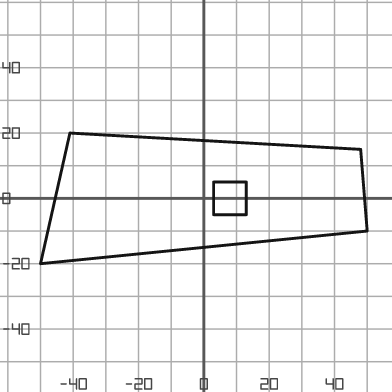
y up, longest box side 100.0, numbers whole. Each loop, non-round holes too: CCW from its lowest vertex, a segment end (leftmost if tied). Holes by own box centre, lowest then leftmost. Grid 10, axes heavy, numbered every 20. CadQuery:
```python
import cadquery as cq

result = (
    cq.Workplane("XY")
    .moveTo(-50.0, -20.0)
    .lineTo(50.0, -10.0)
    .lineTo(48.0, 15.0)
    .lineTo(-41.0, 20.0)
    .close()
    .moveTo(3.0, -5.0)
    .lineTo(13.0, -5.0)
    .lineTo(13.0, 5.0)
    .lineTo(3.0, 5.0)
    .close()
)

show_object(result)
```